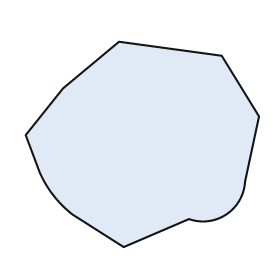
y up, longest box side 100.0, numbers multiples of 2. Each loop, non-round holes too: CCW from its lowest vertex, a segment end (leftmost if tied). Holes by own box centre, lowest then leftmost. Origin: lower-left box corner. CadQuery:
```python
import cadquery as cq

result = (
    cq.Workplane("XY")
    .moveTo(42.0, 0.0)
    .lineTo(70.0, 12.0)
    .threePointArc((86.0, 14.0), (94.0, 28.0))
    .lineTo(100.0, 56.0)
    .lineTo(84.0, 82.0)
    .lineTo(40.0, 88.0)
    .lineTo(16.0, 68.0)
    .lineTo(0.0, 48.0)
    .lineTo(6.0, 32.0)
    .threePointArc((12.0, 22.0), (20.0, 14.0))
    .close()
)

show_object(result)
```